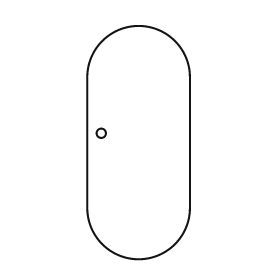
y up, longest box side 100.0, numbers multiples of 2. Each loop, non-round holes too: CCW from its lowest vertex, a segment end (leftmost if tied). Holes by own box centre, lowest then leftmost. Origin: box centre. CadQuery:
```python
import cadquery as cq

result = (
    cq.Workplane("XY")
    .moveTo(-22.0, -28.0)
    .threePointArc((0.0, -50.0), (22.0, -28.0))
    .lineTo(22.0, 28.0)
    .threePointArc((0.0, 50.0), (-22.0, 28.0))
    .close()
    .moveTo(-16.0, 4.0)
    .circle(2.0)
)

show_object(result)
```